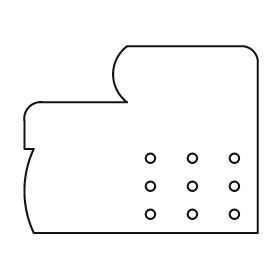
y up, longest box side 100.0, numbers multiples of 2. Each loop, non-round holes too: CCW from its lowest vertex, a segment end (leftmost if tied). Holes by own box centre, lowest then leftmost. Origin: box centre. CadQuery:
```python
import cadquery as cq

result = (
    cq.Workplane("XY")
    .moveTo(-46.0, -40.0)
    .lineTo(50.0, -40.0)
    .lineTo(50.0, 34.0)
    .threePointArc((48.0, 38.0), (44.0, 40.0))
    .lineTo(-6.0, 40.0)
    .threePointArc((-12.0, 28.0), (-6.0, 16.0))
    .lineTo(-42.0, 16.0)
    .threePointArc((-48.0, 14.0), (-50.0, 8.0))
    .lineTo(-50.0, -4.0)
    .lineTo(-46.0, -4.0)
    .threePointArc((-50.0, -22.0), (-46.0, -40.0))
    .close()
    .moveTo(4.0, -32.0)
    .circle(2.0)
    .moveTo(22.0, -32.0)
    .circle(2.0)
    .moveTo(40.0, -32.0)
    .circle(2.0)
    .moveTo(4.0, -20.0)
    .circle(2.0)
    .moveTo(22.0, -20.0)
    .circle(2.0)
    .moveTo(40.0, -20.0)
    .circle(2.0)
    .moveTo(4.0, -8.0)
    .circle(2.0)
    .moveTo(22.0, -8.0)
    .circle(2.0)
    .moveTo(40.0, -8.0)
    .circle(2.0)
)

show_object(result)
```